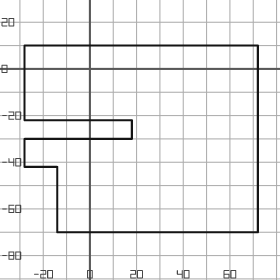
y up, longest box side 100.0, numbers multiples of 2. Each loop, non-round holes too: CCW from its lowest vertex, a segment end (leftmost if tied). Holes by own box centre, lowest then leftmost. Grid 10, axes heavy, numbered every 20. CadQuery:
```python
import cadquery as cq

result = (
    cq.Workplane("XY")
    .moveTo(-14.0, -70.0)
    .lineTo(72.0, -70.0)
    .lineTo(72.0, 10.0)
    .lineTo(-28.0, 10.0)
    .lineTo(-28.0, -22.0)
    .lineTo(18.0, -22.0)
    .lineTo(18.0, -30.0)
    .lineTo(-28.0, -30.0)
    .lineTo(-28.0, -42.0)
    .lineTo(-14.0, -42.0)
    .close()
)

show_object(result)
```